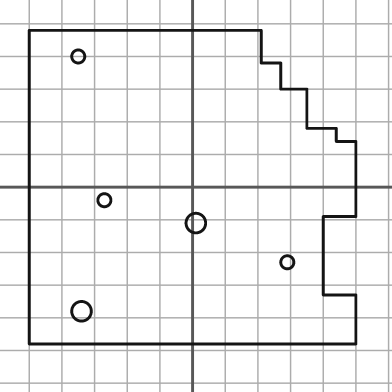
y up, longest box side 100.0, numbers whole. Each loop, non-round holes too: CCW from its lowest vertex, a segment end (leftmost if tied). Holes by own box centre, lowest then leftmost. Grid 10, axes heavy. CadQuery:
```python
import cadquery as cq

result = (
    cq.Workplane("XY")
    .moveTo(-50.0, -48.0)
    .lineTo(50.0, -48.0)
    .lineTo(50.0, -33.0)
    .lineTo(40.0, -33.0)
    .lineTo(40.0, -9.0)
    .lineTo(50.0, -9.0)
    .lineTo(50.0, 14.0)
    .lineTo(44.0, 14.0)
    .lineTo(44.0, 18.0)
    .lineTo(35.0, 18.0)
    .lineTo(35.0, 30.0)
    .lineTo(27.0, 30.0)
    .lineTo(27.0, 38.0)
    .lineTo(21.0, 38.0)
    .lineTo(21.0, 48.0)
    .lineTo(-50.0, 48.0)
    .close()
    .moveTo(-34.0, -38.0)
    .circle(3.0)
    .moveTo(29.0, -23.0)
    .circle(2.0)
    .moveTo(1.0, -11.0)
    .circle(3.0)
    .moveTo(-27.0, -4.0)
    .circle(2.0)
    .moveTo(-35.0, 40.0)
    .circle(2.0)
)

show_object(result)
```